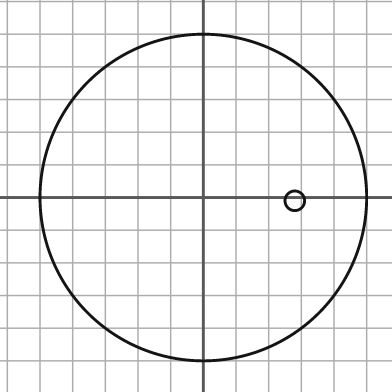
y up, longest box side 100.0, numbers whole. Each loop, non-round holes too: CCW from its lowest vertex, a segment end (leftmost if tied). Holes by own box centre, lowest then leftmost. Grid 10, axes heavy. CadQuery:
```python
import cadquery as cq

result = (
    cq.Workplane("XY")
    .moveTo(0.0, 0.0)
    .circle(50.0)
    .moveTo(28.0, -1.0)
    .circle(3.0)
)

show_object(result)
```